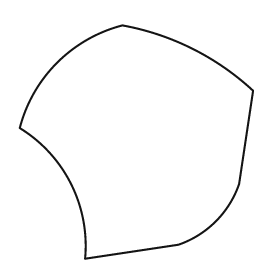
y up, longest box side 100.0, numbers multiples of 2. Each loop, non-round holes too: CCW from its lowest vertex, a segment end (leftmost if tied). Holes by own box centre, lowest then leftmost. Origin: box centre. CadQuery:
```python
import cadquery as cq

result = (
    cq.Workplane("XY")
    .moveTo(-22.0, -50.0)
    .lineTo(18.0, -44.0)
    .threePointArc((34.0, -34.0), (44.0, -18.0))
    .lineTo(50.0, 22.0)
    .threePointArc((24.0, 40.0), (-6.0, 50.0))
    .threePointArc((-34.0, 34.0), (-50.0, 6.0))
    .threePointArc((-28.0, -18.0), (-22.0, -50.0))
    .close()
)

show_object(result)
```